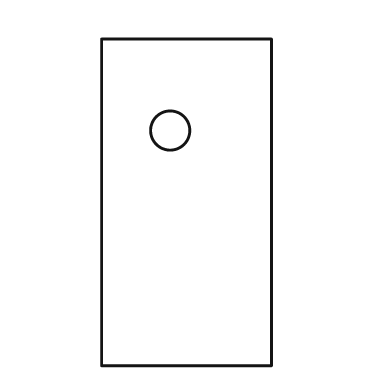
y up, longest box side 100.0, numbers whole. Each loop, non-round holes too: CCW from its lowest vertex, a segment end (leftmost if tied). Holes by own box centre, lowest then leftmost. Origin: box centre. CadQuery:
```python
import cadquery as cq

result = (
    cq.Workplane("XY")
    .moveTo(-26.0, -50.0)
    .lineTo(26.0, -50.0)
    .lineTo(26.0, 50.0)
    .lineTo(-26.0, 50.0)
    .close()
    .moveTo(-5.0, 22.0)
    .circle(6.0)
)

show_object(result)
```